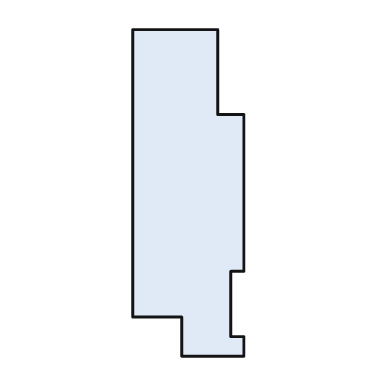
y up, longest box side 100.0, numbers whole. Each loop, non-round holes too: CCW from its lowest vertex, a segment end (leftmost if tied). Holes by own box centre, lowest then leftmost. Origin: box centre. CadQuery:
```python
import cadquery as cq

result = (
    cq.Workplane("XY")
    .moveTo(-2.0, -50.0)
    .lineTo(17.0, -50.0)
    .lineTo(17.0, -44.0)
    .lineTo(13.0, -44.0)
    .lineTo(13.0, -24.0)
    .lineTo(17.0, -24.0)
    .lineTo(17.0, 24.0)
    .lineTo(9.0, 24.0)
    .lineTo(9.0, 50.0)
    .lineTo(-17.0, 50.0)
    .lineTo(-17.0, -38.0)
    .lineTo(-2.0, -38.0)
    .close()
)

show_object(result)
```